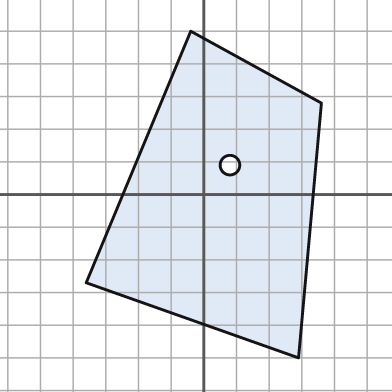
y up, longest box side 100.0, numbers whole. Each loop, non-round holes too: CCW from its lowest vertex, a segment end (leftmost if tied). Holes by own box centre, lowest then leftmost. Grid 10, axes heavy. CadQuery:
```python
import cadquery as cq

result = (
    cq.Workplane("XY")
    .moveTo(29.0, -50.0)
    .lineTo(36.0, 28.0)
    .lineTo(-4.0, 50.0)
    .lineTo(-36.0, -27.0)
    .close()
    .moveTo(8.0, 9.0)
    .circle(3.0)
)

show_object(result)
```